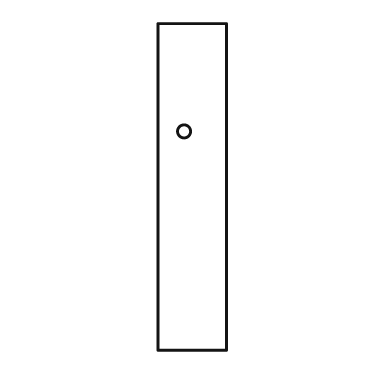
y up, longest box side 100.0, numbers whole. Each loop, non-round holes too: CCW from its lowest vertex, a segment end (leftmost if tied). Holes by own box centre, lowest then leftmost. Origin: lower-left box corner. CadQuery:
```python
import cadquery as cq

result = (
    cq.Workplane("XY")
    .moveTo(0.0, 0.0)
    .lineTo(21.0, 0.0)
    .lineTo(21.0, 100.0)
    .lineTo(0.0, 100.0)
    .close()
    .moveTo(8.0, 67.0)
    .circle(2.0)
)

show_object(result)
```